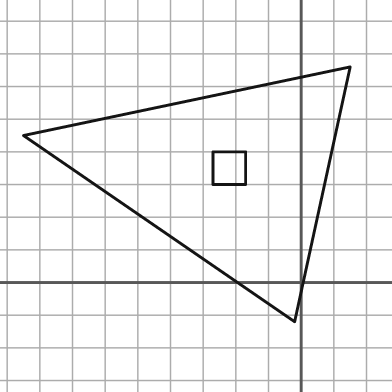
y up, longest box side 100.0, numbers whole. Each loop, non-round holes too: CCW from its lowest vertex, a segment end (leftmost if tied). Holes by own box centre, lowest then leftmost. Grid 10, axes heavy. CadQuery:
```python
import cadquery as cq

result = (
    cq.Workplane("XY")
    .moveTo(-2.0, -12.0)
    .lineTo(15.0, 66.0)
    .lineTo(-85.0, 45.0)
    .close()
    .moveTo(-27.0, 30.0)
    .lineTo(-17.0, 30.0)
    .lineTo(-17.0, 40.0)
    .lineTo(-27.0, 40.0)
    .close()
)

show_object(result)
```